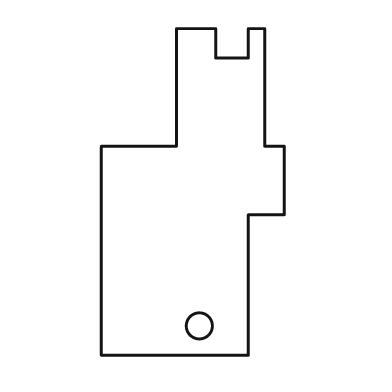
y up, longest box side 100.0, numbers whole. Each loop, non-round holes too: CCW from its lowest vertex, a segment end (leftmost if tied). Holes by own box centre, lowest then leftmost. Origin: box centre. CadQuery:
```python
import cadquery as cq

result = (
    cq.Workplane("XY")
    .moveTo(-28.0, -50.0)
    .lineTo(17.0, -50.0)
    .lineTo(17.0, -7.0)
    .lineTo(28.0, -7.0)
    .lineTo(28.0, 14.0)
    .lineTo(22.0, 14.0)
    .lineTo(22.0, 50.0)
    .lineTo(17.0, 50.0)
    .lineTo(17.0, 41.0)
    .lineTo(7.0, 41.0)
    .lineTo(7.0, 50.0)
    .lineTo(-5.0, 50.0)
    .lineTo(-5.0, 14.0)
    .lineTo(-28.0, 14.0)
    .close()
    .moveTo(2.0, -41.0)
    .circle(4.0)
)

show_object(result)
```